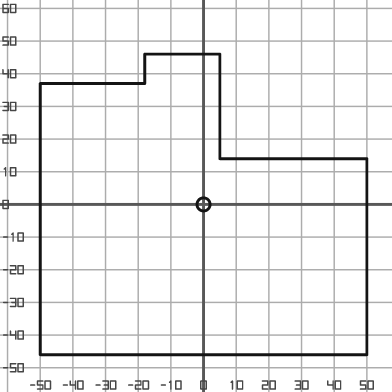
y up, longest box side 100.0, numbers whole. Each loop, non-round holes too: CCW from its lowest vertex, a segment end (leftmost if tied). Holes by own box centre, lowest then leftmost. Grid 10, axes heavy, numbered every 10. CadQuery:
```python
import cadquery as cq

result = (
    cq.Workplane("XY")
    .moveTo(-50.0, -46.0)
    .lineTo(50.0, -46.0)
    .lineTo(50.0, 14.0)
    .lineTo(5.0, 14.0)
    .lineTo(5.0, 46.0)
    .lineTo(-18.0, 46.0)
    .lineTo(-18.0, 37.0)
    .lineTo(-50.0, 37.0)
    .close()
    .moveTo(0.0, 0.0)
    .circle(2.0)
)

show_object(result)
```